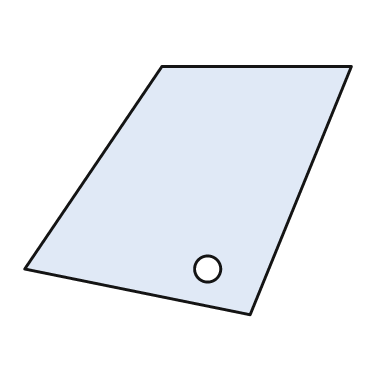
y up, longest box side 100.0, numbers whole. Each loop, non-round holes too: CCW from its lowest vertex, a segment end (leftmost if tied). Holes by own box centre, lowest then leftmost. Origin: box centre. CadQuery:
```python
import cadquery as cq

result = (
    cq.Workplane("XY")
    .moveTo(19.0, -38.0)
    .lineTo(50.0, 38.0)
    .lineTo(-8.0, 38.0)
    .lineTo(-50.0, -24.0)
    .close()
    .moveTo(6.0, -24.0)
    .circle(4.0)
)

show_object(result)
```